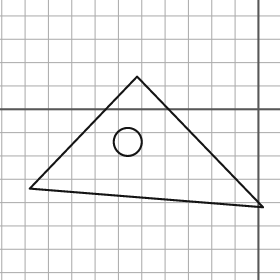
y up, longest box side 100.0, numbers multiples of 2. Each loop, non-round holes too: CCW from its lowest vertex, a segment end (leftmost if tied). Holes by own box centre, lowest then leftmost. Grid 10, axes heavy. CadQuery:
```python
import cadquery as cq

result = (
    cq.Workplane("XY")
    .moveTo(2.0, -42.0)
    .lineTo(-52.0, 14.0)
    .lineTo(-98.0, -34.0)
    .close()
    .moveTo(-56.0, -14.0)
    .circle(6.0)
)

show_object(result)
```